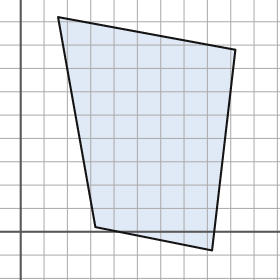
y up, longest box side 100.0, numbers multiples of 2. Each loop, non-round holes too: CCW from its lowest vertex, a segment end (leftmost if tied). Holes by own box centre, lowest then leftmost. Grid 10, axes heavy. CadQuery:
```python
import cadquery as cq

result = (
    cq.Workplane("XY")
    .moveTo(82.0, -8.0)
    .lineTo(92.0, 78.0)
    .lineTo(16.0, 92.0)
    .lineTo(32.0, 2.0)
    .close()
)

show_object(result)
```